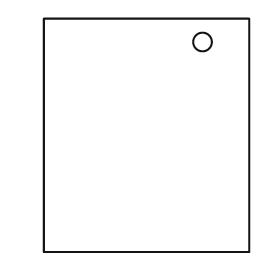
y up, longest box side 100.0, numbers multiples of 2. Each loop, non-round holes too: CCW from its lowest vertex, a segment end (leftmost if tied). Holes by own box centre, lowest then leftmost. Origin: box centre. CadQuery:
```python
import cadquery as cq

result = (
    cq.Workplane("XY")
    .moveTo(-44.0, -50.0)
    .lineTo(44.0, -50.0)
    .lineTo(44.0, 50.0)
    .lineTo(-44.0, 50.0)
    .close()
    .moveTo(24.0, 40.0)
    .circle(4.0)
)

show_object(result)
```